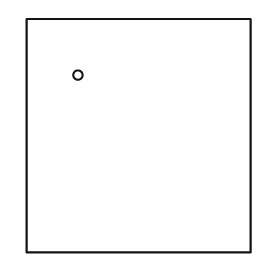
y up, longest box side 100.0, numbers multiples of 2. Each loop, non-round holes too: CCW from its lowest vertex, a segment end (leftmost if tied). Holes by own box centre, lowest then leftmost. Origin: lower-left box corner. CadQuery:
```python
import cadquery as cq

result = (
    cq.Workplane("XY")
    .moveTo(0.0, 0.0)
    .lineTo(96.0, 0.0)
    .lineTo(96.0, 100.0)
    .lineTo(0.0, 100.0)
    .close()
    .moveTo(22.0, 76.0)
    .circle(2.0)
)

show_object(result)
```